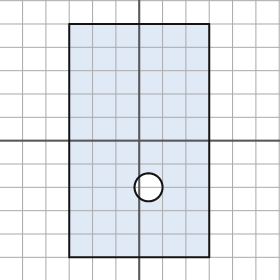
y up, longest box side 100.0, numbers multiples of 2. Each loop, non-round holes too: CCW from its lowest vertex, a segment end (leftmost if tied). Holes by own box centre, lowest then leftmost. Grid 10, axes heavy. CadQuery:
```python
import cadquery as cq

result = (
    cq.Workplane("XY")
    .moveTo(-30.0, -50.0)
    .lineTo(30.0, -50.0)
    .lineTo(30.0, 50.0)
    .lineTo(-30.0, 50.0)
    .close()
    .moveTo(4.0, -20.0)
    .circle(6.0)
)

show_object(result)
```